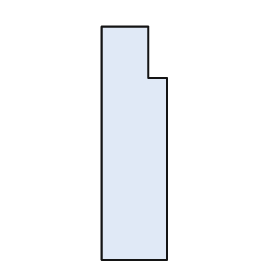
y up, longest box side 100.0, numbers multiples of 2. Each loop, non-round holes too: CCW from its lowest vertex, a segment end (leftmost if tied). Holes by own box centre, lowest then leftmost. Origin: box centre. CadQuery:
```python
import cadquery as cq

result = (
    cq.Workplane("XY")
    .moveTo(-14.0, -50.0)
    .lineTo(14.0, -50.0)
    .lineTo(14.0, 28.0)
    .lineTo(6.0, 28.0)
    .lineTo(6.0, 50.0)
    .lineTo(-14.0, 50.0)
    .close()
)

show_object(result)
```